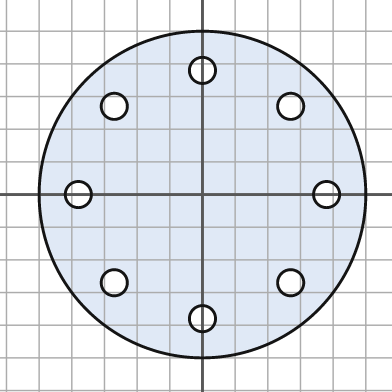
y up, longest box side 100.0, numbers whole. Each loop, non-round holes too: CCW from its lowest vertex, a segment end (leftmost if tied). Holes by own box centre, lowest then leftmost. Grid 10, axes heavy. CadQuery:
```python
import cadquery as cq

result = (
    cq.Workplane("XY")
    .moveTo(0.0, 0.0)
    .circle(50.0)
    .moveTo(0.0, -38.0)
    .circle(4.0)
    .moveTo(-27.0, -27.0)
    .circle(4.0)
    .moveTo(27.0, -27.0)
    .circle(4.0)
    .moveTo(-38.0, 0.0)
    .circle(4.0)
    .moveTo(38.0, 0.0)
    .circle(4.0)
    .moveTo(-27.0, 27.0)
    .circle(4.0)
    .moveTo(27.0, 27.0)
    .circle(4.0)
    .moveTo(0.0, 38.0)
    .circle(4.0)
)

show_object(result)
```